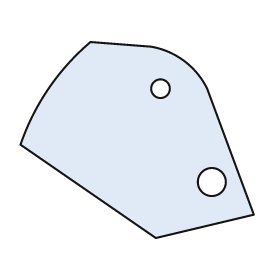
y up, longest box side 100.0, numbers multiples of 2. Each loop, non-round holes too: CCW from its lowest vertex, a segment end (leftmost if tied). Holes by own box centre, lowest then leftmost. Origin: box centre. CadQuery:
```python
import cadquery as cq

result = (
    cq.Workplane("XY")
    .moveTo(8.0, -42.0)
    .lineTo(50.0, -32.0)
    .lineTo(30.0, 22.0)
    .threePointArc((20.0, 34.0), (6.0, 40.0))
    .lineTo(-20.0, 42.0)
    .threePointArc((-38.0, 22.0), (-50.0, -2.0))
    .close()
    .moveTo(32.0, -18.0)
    .circle(6.0)
    .moveTo(10.0, 22.0)
    .circle(4.0)
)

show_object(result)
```